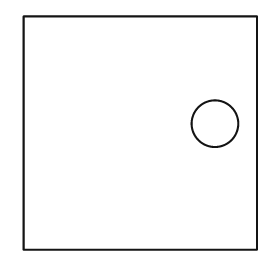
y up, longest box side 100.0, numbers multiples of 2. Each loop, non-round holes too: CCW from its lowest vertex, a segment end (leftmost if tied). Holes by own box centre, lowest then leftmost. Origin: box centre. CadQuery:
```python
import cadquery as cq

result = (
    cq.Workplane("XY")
    .moveTo(-50.0, -50.0)
    .lineTo(50.0, -50.0)
    .lineTo(50.0, 50.0)
    .lineTo(-50.0, 50.0)
    .close()
    .moveTo(32.0, 4.0)
    .circle(10.0)
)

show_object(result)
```